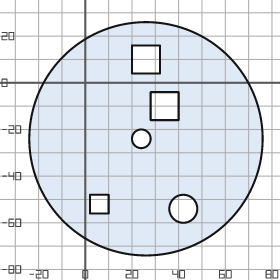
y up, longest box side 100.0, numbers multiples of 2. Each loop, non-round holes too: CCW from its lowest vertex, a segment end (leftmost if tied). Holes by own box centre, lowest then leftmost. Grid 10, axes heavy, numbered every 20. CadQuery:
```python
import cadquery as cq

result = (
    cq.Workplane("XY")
    .moveTo(26.0, -24.0)
    .circle(50.0)
    .moveTo(42.0, -54.0)
    .circle(6.0)
    .moveTo(2.0, -56.0)
    .lineTo(10.0, -56.0)
    .lineTo(10.0, -48.0)
    .lineTo(2.0, -48.0)
    .close()
    .moveTo(24.0, -24.0)
    .circle(4.0)
    .moveTo(28.0, -16.0)
    .lineTo(40.0, -16.0)
    .lineTo(40.0, -4.0)
    .lineTo(28.0, -4.0)
    .close()
    .moveTo(20.0, 4.0)
    .lineTo(32.0, 4.0)
    .lineTo(32.0, 16.0)
    .lineTo(20.0, 16.0)
    .close()
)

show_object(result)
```